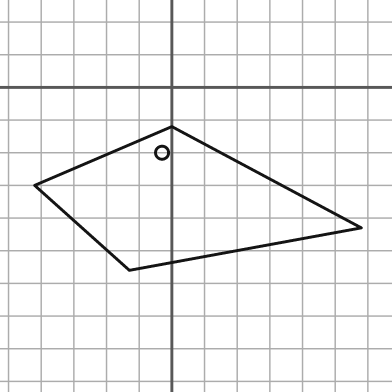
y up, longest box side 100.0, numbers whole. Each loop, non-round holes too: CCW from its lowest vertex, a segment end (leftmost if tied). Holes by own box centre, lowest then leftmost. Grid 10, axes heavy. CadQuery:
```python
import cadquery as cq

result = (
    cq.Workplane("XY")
    .moveTo(-13.0, -56.0)
    .lineTo(58.0, -43.0)
    .lineTo(0.0, -12.0)
    .lineTo(-42.0, -30.0)
    .close()
    .moveTo(-3.0, -20.0)
    .circle(2.0)
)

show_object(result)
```